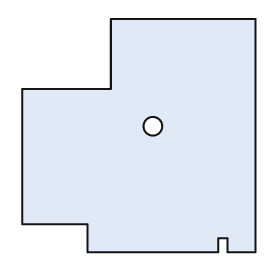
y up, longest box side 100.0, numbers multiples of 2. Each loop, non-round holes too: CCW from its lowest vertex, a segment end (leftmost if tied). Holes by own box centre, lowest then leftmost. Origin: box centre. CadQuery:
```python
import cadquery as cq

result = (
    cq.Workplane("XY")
    .moveTo(-22.0, -50.0)
    .lineTo(34.0, -50.0)
    .lineTo(34.0, -44.0)
    .lineTo(38.0, -44.0)
    .lineTo(38.0, -50.0)
    .lineTo(50.0, -50.0)
    .lineTo(50.0, 50.0)
    .lineTo(-12.0, 50.0)
    .lineTo(-12.0, 20.0)
    .lineTo(-50.0, 20.0)
    .lineTo(-50.0, -38.0)
    .lineTo(-22.0, -38.0)
    .close()
    .moveTo(6.0, 4.0)
    .circle(4.0)
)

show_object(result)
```